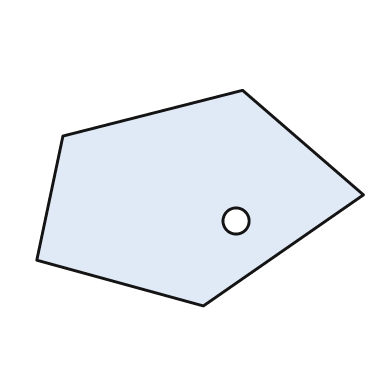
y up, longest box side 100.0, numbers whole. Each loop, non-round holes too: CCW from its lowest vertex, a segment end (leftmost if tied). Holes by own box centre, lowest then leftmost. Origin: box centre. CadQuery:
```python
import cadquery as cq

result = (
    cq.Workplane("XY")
    .moveTo(1.0, -33.0)
    .lineTo(50.0, 1.0)
    .lineTo(13.0, 33.0)
    .lineTo(-42.0, 19.0)
    .lineTo(-50.0, -19.0)
    .close()
    .moveTo(11.0, -7.0)
    .circle(4.0)
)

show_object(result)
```